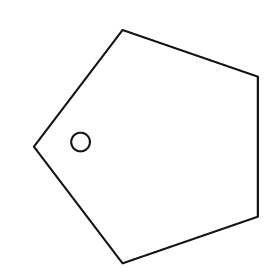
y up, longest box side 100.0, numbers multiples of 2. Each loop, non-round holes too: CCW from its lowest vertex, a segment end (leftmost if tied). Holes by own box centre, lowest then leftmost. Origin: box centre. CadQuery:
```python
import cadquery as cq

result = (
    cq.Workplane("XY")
    .moveTo(-10.0, -50.0)
    .lineTo(48.0, -30.0)
    .lineTo(48.0, 30.0)
    .lineTo(-10.0, 50.0)
    .lineTo(-48.0, 0.0)
    .close()
    .moveTo(-28.0, 2.0)
    .circle(4.0)
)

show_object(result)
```